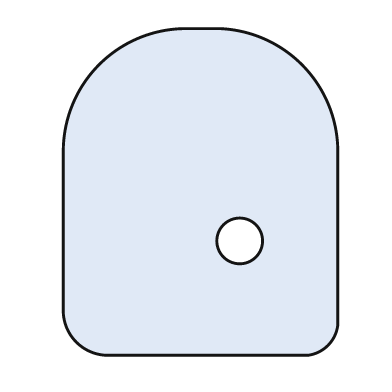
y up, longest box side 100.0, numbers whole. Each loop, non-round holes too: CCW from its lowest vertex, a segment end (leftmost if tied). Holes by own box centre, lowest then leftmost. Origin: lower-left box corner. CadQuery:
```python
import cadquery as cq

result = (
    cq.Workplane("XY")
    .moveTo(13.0, 0.0)
    .lineTo(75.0, 0.0)
    .threePointArc((81.0, 3.0), (84.0, 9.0))
    .lineTo(84.0, 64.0)
    .threePointArc((73.0, 89.0), (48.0, 100.0))
    .lineTo(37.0, 100.0)
    .threePointArc((11.0, 89.0), (0.0, 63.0))
    .lineTo(0.0, 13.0)
    .threePointArc((4.0, 4.0), (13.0, 0.0))
    .close()
    .moveTo(54.0, 35.0)
    .circle(7.0)
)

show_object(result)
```